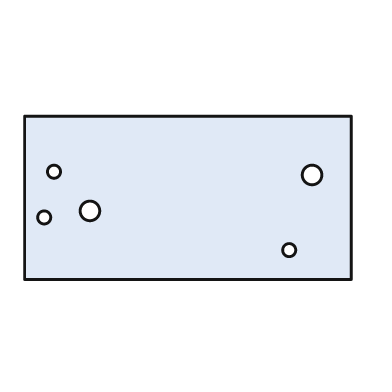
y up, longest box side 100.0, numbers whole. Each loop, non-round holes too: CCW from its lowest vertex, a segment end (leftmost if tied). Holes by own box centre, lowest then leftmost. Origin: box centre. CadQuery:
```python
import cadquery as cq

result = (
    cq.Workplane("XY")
    .moveTo(-50.0, -25.0)
    .lineTo(50.0, -25.0)
    .lineTo(50.0, 25.0)
    .lineTo(-50.0, 25.0)
    .close()
    .moveTo(31.0, -16.0)
    .circle(2.0)
    .moveTo(-44.0, -6.0)
    .circle(2.0)
    .moveTo(-30.0, -4.0)
    .circle(3.0)
    .moveTo(38.0, 7.0)
    .circle(3.0)
    .moveTo(-41.0, 8.0)
    .circle(2.0)
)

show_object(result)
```